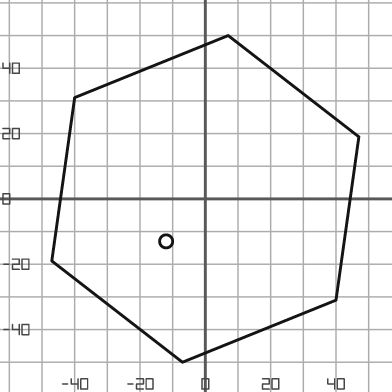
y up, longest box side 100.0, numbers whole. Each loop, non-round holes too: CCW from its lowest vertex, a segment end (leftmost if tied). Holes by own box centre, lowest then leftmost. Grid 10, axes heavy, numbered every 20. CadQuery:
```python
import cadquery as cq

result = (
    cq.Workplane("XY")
    .moveTo(-7.0, -50.0)
    .lineTo(40.0, -31.0)
    .lineTo(47.0, 19.0)
    .lineTo(7.0, 50.0)
    .lineTo(-40.0, 31.0)
    .lineTo(-47.0, -19.0)
    .close()
    .moveTo(-12.0, -13.0)
    .circle(2.0)
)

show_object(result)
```